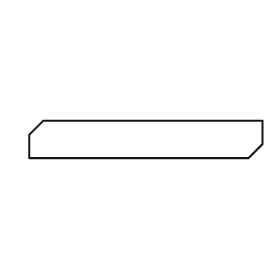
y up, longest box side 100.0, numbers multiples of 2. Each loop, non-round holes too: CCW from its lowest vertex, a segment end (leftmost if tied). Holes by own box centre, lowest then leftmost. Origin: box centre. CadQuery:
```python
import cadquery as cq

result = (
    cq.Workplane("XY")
    .moveTo(-50.0, -8.0)
    .lineTo(44.0, -8.0)
    .lineTo(50.0, -2.0)
    .lineTo(50.0, 8.0)
    .lineTo(-44.0, 8.0)
    .lineTo(-50.0, 2.0)
    .close()
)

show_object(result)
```